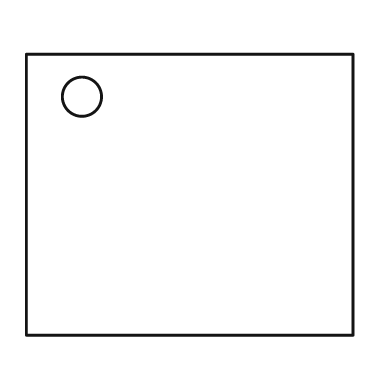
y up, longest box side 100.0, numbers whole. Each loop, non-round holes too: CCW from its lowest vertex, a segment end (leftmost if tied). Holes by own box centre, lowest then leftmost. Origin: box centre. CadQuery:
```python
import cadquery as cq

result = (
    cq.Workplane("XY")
    .moveTo(-50.0, -43.0)
    .lineTo(50.0, -43.0)
    .lineTo(50.0, 43.0)
    .lineTo(-50.0, 43.0)
    .close()
    .moveTo(-33.0, 30.0)
    .circle(6.0)
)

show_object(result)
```